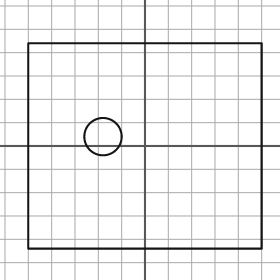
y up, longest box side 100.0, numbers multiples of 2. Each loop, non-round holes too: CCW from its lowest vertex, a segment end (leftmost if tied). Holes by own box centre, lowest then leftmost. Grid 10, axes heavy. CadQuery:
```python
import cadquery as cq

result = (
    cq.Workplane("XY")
    .moveTo(-50.0, -44.0)
    .lineTo(50.0, -44.0)
    .lineTo(50.0, 44.0)
    .lineTo(-50.0, 44.0)
    .close()
    .moveTo(-18.0, 4.0)
    .circle(8.0)
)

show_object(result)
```